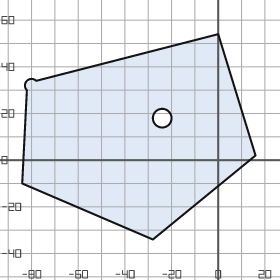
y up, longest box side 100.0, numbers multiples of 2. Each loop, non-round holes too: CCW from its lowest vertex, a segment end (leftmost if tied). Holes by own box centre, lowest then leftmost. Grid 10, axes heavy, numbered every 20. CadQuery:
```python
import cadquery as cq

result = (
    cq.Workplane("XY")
    .moveTo(-28.0, -34.0)
    .lineTo(16.0, 2.0)
    .lineTo(0.0, 54.0)
    .lineTo(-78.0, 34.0)
    .threePointArc((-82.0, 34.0), (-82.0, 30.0))
    .lineTo(-84.0, -10.0)
    .close()
    .moveTo(-24.0, 18.0)
    .circle(4.0)
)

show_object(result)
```